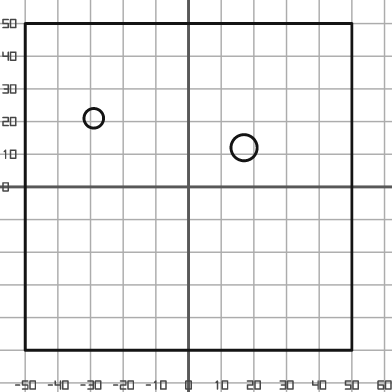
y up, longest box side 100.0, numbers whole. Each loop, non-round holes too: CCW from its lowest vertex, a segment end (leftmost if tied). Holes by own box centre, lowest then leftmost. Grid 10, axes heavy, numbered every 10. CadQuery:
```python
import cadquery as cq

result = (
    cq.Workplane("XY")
    .moveTo(-50.0, -50.0)
    .lineTo(50.0, -50.0)
    .lineTo(50.0, 50.0)
    .lineTo(-50.0, 50.0)
    .close()
    .moveTo(17.0, 12.0)
    .circle(4.0)
    .moveTo(-29.0, 21.0)
    .circle(3.0)
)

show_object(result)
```